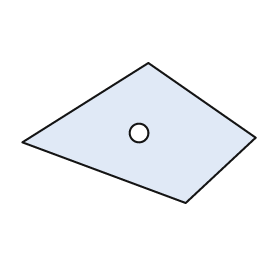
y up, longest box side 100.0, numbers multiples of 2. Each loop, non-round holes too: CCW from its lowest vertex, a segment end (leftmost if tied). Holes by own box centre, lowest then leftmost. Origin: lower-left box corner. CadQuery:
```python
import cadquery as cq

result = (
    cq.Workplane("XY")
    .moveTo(70.0, 0.0)
    .lineTo(100.0, 28.0)
    .lineTo(54.0, 60.0)
    .lineTo(0.0, 26.0)
    .close()
    .moveTo(50.0, 30.0)
    .circle(4.0)
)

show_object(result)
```